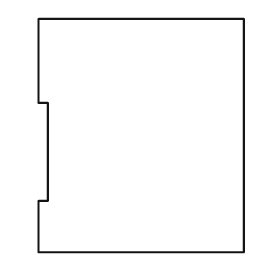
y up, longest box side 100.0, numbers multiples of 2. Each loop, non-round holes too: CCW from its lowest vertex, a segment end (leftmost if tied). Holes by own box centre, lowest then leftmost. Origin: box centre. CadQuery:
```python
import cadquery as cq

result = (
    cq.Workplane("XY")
    .moveTo(-44.0, -50.0)
    .lineTo(44.0, -50.0)
    .lineTo(44.0, 50.0)
    .lineTo(-44.0, 50.0)
    .lineTo(-44.0, 14.0)
    .lineTo(-40.0, 14.0)
    .lineTo(-40.0, -28.0)
    .lineTo(-44.0, -28.0)
    .close()
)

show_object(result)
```